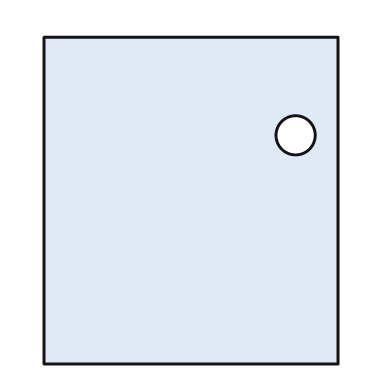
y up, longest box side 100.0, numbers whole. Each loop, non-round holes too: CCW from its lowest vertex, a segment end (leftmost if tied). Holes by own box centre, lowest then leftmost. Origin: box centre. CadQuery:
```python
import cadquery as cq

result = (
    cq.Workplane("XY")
    .moveTo(-45.0, -50.0)
    .lineTo(45.0, -50.0)
    .lineTo(45.0, 50.0)
    .lineTo(-45.0, 50.0)
    .close()
    .moveTo(32.0, 20.0)
    .circle(6.0)
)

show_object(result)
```